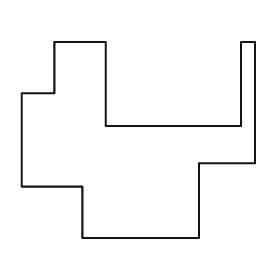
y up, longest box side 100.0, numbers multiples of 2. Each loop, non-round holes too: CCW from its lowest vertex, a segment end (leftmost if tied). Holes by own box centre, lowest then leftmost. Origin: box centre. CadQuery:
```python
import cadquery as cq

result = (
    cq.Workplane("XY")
    .moveTo(-24.0, -42.0)
    .lineTo(26.0, -42.0)
    .lineTo(26.0, -10.0)
    .lineTo(50.0, -10.0)
    .lineTo(50.0, 42.0)
    .lineTo(44.0, 42.0)
    .lineTo(44.0, 6.0)
    .lineTo(-14.0, 6.0)
    .lineTo(-14.0, 42.0)
    .lineTo(-36.0, 42.0)
    .lineTo(-36.0, 20.0)
    .lineTo(-50.0, 20.0)
    .lineTo(-50.0, -20.0)
    .lineTo(-24.0, -20.0)
    .close()
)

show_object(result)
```